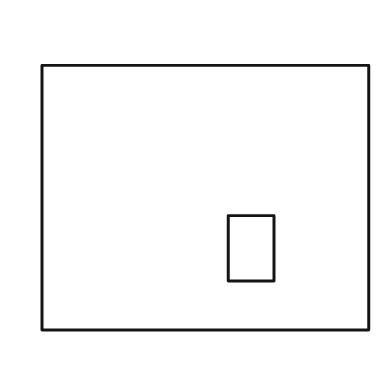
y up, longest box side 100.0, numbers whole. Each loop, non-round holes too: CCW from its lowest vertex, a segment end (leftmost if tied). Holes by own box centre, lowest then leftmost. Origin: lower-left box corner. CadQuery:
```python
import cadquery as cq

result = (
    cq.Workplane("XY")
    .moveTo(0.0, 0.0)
    .lineTo(100.0, 0.0)
    .lineTo(100.0, 81.0)
    .lineTo(0.0, 81.0)
    .close()
    .moveTo(57.0, 15.0)
    .lineTo(71.0, 15.0)
    .lineTo(71.0, 35.0)
    .lineTo(57.0, 35.0)
    .close()
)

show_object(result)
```